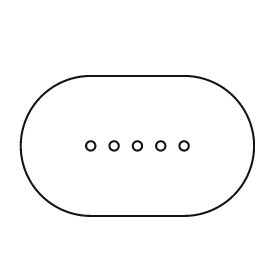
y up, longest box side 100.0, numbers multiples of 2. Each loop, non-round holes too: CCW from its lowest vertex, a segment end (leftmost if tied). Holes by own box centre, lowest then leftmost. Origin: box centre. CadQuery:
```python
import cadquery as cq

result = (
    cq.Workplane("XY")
    .moveTo(-20.0, -30.0)
    .lineTo(20.0, -30.0)
    .threePointArc((50.0, 0.0), (20.0, 30.0))
    .lineTo(-20.0, 30.0)
    .threePointArc((-50.0, 0.0), (-20.0, -30.0))
    .close()
    .moveTo(-20.0, 0.0)
    .circle(2.0)
    .moveTo(-10.0, 0.0)
    .circle(2.0)
    .moveTo(0.0, 0.0)
    .circle(2.0)
    .moveTo(10.0, 0.0)
    .circle(2.0)
    .moveTo(20.0, 0.0)
    .circle(2.0)
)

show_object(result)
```